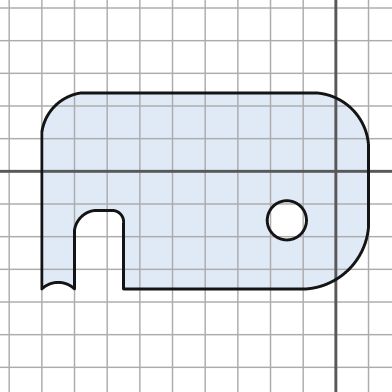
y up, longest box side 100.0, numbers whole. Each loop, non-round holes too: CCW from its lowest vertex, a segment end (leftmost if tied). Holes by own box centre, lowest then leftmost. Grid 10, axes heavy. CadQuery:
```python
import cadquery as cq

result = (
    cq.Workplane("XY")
    .moveTo(-90.0, -36.0)
    .threePointArc((-85.0, -34.0), (-80.0, -36.0))
    .lineTo(-80.0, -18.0)
    .threePointArc((-78.0, -14.0), (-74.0, -12.0))
    .lineTo(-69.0, -12.0)
    .threePointArc((-66.0, -13.0), (-65.0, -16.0))
    .lineTo(-65.0, -36.0)
    .lineTo(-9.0, -36.0)
    .threePointArc((4.0, -30.0), (10.0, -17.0))
    .lineTo(10.0, 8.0)
    .threePointArc((5.0, 19.0), (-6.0, 24.0))
    .lineTo(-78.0, 24.0)
    .threePointArc((-86.0, 20.0), (-90.0, 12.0))
    .close()
    .moveTo(-15.0, -15.0)
    .circle(6.0)
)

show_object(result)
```